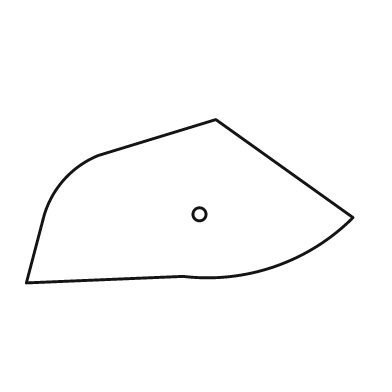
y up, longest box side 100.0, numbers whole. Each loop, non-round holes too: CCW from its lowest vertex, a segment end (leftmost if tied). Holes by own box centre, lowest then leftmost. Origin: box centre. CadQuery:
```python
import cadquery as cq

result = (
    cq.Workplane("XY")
    .moveTo(-50.0, -25.0)
    .lineTo(-2.0, -23.0)
    .threePointArc((26.0, -20.0), (50.0, -5.0))
    .lineTo(8.0, 25.0)
    .lineTo(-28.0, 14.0)
    .threePointArc((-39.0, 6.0), (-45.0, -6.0))
    .close()
    .moveTo(3.0, -4.0)
    .circle(2.0)
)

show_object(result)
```